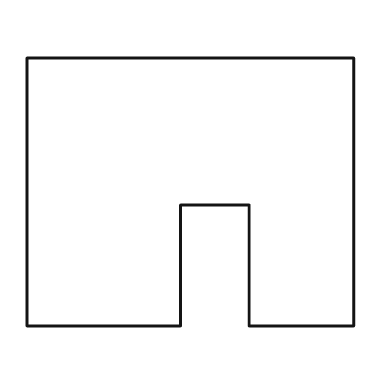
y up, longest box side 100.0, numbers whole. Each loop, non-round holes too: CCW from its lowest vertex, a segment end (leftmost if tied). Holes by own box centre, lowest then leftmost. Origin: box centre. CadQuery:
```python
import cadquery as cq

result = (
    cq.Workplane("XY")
    .moveTo(-50.0, -41.0)
    .lineTo(-3.0, -41.0)
    .lineTo(-3.0, -4.0)
    .lineTo(18.0, -4.0)
    .lineTo(18.0, -41.0)
    .lineTo(50.0, -41.0)
    .lineTo(50.0, 41.0)
    .lineTo(-50.0, 41.0)
    .close()
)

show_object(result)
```